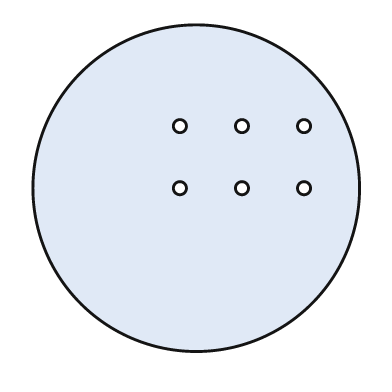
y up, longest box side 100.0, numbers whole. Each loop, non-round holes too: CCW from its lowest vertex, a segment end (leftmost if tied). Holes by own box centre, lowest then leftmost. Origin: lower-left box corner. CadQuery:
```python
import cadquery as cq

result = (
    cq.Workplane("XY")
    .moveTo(50.0, 50.0)
    .circle(50.0)
    .moveTo(45.0, 50.0)
    .circle(2.0)
    .moveTo(64.0, 50.0)
    .circle(2.0)
    .moveTo(83.0, 50.0)
    .circle(2.0)
    .moveTo(45.0, 69.0)
    .circle(2.0)
    .moveTo(64.0, 69.0)
    .circle(2.0)
    .moveTo(83.0, 69.0)
    .circle(2.0)
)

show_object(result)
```